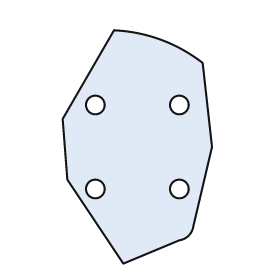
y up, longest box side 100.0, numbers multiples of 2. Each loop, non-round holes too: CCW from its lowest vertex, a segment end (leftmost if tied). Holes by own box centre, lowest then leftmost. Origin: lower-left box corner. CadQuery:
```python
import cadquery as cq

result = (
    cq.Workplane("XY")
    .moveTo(26.0, 0.0)
    .lineTo(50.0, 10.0)
    .threePointArc((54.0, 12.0), (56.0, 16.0))
    .lineTo(64.0, 50.0)
    .lineTo(60.0, 86.0)
    .threePointArc((42.0, 96.0), (22.0, 100.0))
    .lineTo(0.0, 62.0)
    .lineTo(2.0, 36.0)
    .close()
    .moveTo(14.0, 32.0)
    .circle(4.0)
    .moveTo(50.0, 32.0)
    .circle(4.0)
    .moveTo(14.0, 68.0)
    .circle(4.0)
    .moveTo(50.0, 68.0)
    .circle(4.0)
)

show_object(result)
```